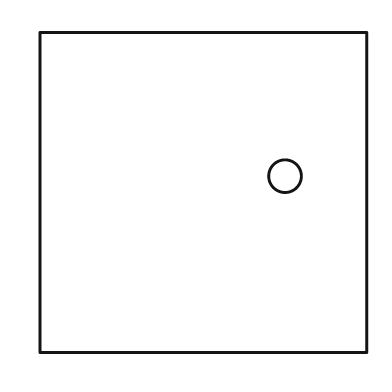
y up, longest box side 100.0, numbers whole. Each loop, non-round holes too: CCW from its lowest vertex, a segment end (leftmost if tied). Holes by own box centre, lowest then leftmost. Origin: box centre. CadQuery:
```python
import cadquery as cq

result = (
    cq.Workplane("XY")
    .moveTo(-50.0, -49.0)
    .lineTo(50.0, -49.0)
    .lineTo(50.0, 49.0)
    .lineTo(-50.0, 49.0)
    .close()
    .moveTo(25.0, 5.0)
    .circle(5.0)
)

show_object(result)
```